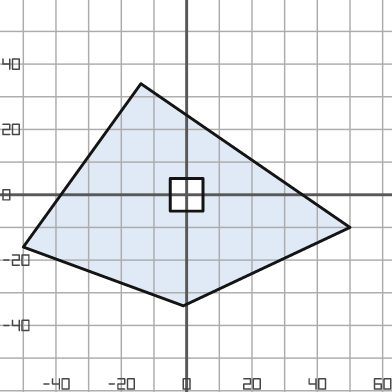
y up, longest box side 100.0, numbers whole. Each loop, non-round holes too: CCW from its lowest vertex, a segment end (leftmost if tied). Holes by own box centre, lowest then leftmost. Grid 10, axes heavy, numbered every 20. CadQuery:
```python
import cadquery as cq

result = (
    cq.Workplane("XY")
    .moveTo(-1.0, -34.0)
    .lineTo(50.0, -10.0)
    .lineTo(-14.0, 34.0)
    .lineTo(-50.0, -16.0)
    .close()
    .moveTo(-5.0, -5.0)
    .lineTo(5.0, -5.0)
    .lineTo(5.0, 5.0)
    .lineTo(-5.0, 5.0)
    .close()
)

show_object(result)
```